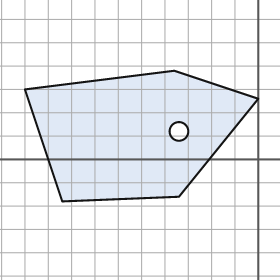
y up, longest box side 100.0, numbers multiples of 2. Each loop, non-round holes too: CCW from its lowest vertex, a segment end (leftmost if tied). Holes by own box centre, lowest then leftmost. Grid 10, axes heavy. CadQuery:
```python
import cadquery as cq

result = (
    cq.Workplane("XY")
    .moveTo(-84.0, -18.0)
    .lineTo(-34.0, -16.0)
    .lineTo(0.0, 26.0)
    .lineTo(-36.0, 38.0)
    .lineTo(-100.0, 30.0)
    .close()
    .moveTo(-34.0, 12.0)
    .circle(4.0)
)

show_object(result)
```